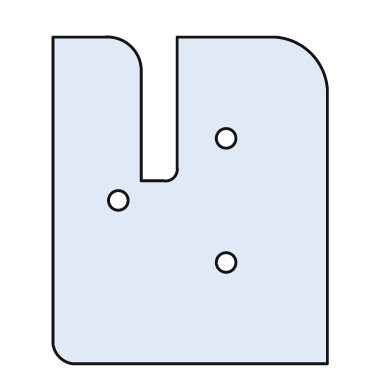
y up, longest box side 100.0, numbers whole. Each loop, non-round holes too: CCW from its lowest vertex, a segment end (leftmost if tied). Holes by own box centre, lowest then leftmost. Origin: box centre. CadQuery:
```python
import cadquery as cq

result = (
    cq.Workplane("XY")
    .moveTo(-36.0, -50.0)
    .lineTo(42.0, -50.0)
    .lineTo(42.0, 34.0)
    .threePointArc((37.0, 45.0), (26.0, 50.0))
    .lineTo(-4.0, 50.0)
    .lineTo(-4.0, 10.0)
    .threePointArc((-5.0, 7.0), (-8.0, 6.0))
    .lineTo(-15.0, 6.0)
    .lineTo(-15.0, 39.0)
    .threePointArc((-18.0, 47.0), (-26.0, 50.0))
    .lineTo(-42.0, 50.0)
    .lineTo(-42.0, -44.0)
    .threePointArc((-40.0, -48.0), (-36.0, -50.0))
    .close()
    .moveTo(11.0, -19.0)
    .circle(3.0)
    .moveTo(-22.0, 0.0)
    .circle(3.0)
    .moveTo(11.0, 19.0)
    .circle(3.0)
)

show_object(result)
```